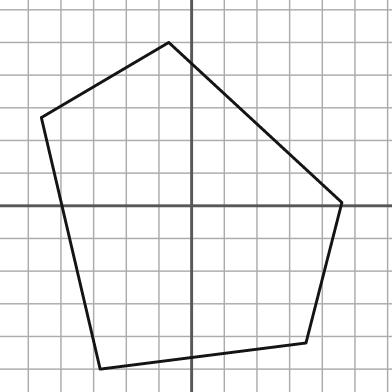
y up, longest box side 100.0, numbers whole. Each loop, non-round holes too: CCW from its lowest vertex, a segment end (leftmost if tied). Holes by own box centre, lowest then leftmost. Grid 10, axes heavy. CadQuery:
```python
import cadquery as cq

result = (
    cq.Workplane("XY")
    .moveTo(-28.0, -50.0)
    .lineTo(35.0, -42.0)
    .lineTo(46.0, 1.0)
    .lineTo(-7.0, 50.0)
    .lineTo(-46.0, 27.0)
    .close()
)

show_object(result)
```